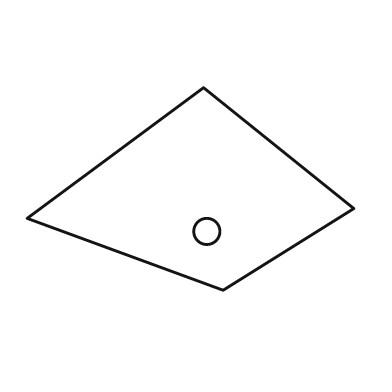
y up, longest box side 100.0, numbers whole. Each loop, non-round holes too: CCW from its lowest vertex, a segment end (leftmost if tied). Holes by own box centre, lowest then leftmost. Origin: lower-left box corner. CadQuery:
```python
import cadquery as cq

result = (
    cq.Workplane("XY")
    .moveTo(60.0, 0.0)
    .lineTo(100.0, 25.0)
    .lineTo(54.0, 62.0)
    .lineTo(0.0, 22.0)
    .close()
    .moveTo(55.0, 18.0)
    .circle(4.0)
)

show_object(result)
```